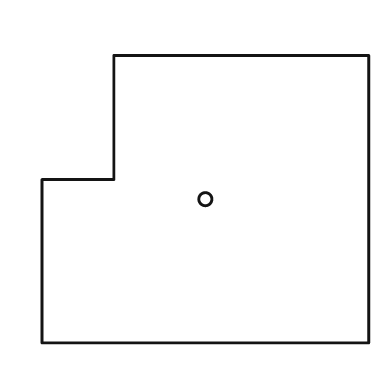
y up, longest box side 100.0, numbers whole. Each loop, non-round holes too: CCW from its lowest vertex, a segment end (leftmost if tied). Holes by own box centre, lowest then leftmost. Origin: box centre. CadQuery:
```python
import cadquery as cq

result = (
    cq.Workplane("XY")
    .moveTo(-50.0, -44.0)
    .lineTo(50.0, -44.0)
    .lineTo(50.0, 44.0)
    .lineTo(-28.0, 44.0)
    .lineTo(-28.0, 6.0)
    .lineTo(-50.0, 6.0)
    .close()
    .moveTo(0.0, 0.0)
    .circle(2.0)
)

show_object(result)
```